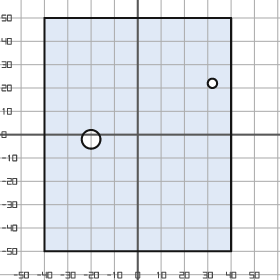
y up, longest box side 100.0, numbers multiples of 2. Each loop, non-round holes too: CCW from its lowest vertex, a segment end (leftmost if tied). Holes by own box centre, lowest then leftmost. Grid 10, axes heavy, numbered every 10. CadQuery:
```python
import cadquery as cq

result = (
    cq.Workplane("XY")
    .moveTo(-40.0, -50.0)
    .lineTo(40.0, -50.0)
    .lineTo(40.0, 50.0)
    .lineTo(-40.0, 50.0)
    .close()
    .moveTo(-20.0, -2.0)
    .circle(4.0)
    .moveTo(32.0, 22.0)
    .circle(2.0)
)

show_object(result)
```